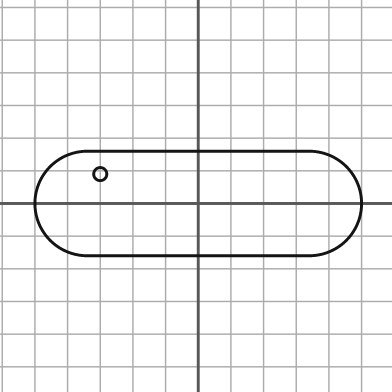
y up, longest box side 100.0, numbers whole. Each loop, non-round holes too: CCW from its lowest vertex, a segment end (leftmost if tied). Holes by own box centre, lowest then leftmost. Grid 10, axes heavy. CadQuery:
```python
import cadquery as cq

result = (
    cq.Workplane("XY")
    .moveTo(-34.0, -16.0)
    .lineTo(34.0, -16.0)
    .threePointArc((50.0, 0.0), (34.0, 16.0))
    .lineTo(-34.0, 16.0)
    .threePointArc((-50.0, 0.0), (-34.0, -16.0))
    .close()
    .moveTo(-30.0, 9.0)
    .circle(2.0)
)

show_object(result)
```